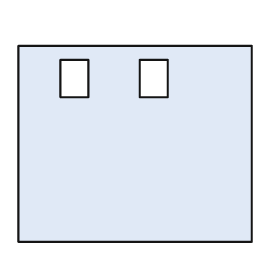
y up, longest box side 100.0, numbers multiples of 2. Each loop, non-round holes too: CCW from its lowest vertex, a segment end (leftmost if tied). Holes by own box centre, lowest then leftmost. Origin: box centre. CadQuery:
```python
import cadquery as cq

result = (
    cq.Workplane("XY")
    .moveTo(-50.0, -42.0)
    .lineTo(50.0, -42.0)
    .lineTo(50.0, 42.0)
    .lineTo(-50.0, 42.0)
    .close()
    .moveTo(-32.0, 20.0)
    .lineTo(-20.0, 20.0)
    .lineTo(-20.0, 36.0)
    .lineTo(-32.0, 36.0)
    .close()
    .moveTo(2.0, 20.0)
    .lineTo(14.0, 20.0)
    .lineTo(14.0, 36.0)
    .lineTo(2.0, 36.0)
    .close()
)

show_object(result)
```